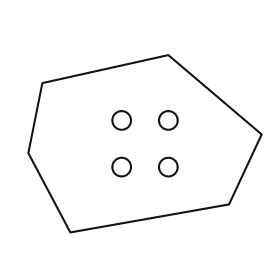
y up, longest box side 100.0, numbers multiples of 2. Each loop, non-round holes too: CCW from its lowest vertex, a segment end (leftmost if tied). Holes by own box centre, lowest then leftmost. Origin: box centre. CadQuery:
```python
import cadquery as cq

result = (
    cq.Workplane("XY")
    .moveTo(-32.0, -38.0)
    .lineTo(36.0, -26.0)
    .lineTo(50.0, 4.0)
    .lineTo(10.0, 38.0)
    .lineTo(-44.0, 26.0)
    .lineTo(-50.0, -4.0)
    .close()
    .moveTo(-10.0, -10.0)
    .circle(4.0)
    .moveTo(10.0, -10.0)
    .circle(4.0)
    .moveTo(-10.0, 10.0)
    .circle(4.0)
    .moveTo(10.0, 10.0)
    .circle(4.0)
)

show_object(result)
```